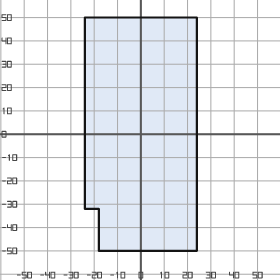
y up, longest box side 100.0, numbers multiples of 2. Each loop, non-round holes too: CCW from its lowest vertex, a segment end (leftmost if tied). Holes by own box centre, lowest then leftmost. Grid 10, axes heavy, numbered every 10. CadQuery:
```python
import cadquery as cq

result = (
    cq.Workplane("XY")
    .moveTo(-18.0, -50.0)
    .lineTo(24.0, -50.0)
    .lineTo(24.0, 50.0)
    .lineTo(-24.0, 50.0)
    .lineTo(-24.0, -32.0)
    .lineTo(-18.0, -32.0)
    .close()
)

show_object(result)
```